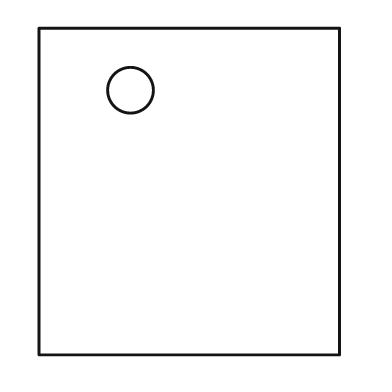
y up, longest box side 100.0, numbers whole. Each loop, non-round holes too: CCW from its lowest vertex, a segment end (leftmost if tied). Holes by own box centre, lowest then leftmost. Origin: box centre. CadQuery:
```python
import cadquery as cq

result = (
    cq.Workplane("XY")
    .moveTo(-46.0, -50.0)
    .lineTo(46.0, -50.0)
    .lineTo(46.0, 50.0)
    .lineTo(-46.0, 50.0)
    .close()
    .moveTo(-18.0, 31.0)
    .circle(7.0)
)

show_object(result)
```